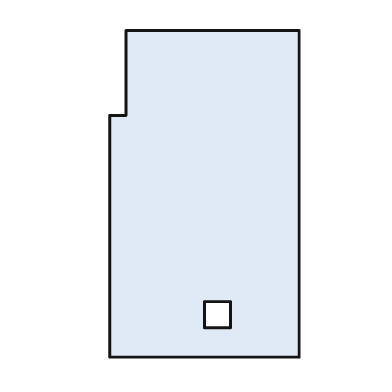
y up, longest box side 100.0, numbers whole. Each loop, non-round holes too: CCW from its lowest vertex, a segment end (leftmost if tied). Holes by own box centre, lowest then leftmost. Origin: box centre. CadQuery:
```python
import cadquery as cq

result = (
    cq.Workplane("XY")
    .moveTo(-29.0, -50.0)
    .lineTo(29.0, -50.0)
    .lineTo(29.0, 50.0)
    .lineTo(-24.0, 50.0)
    .lineTo(-24.0, 24.0)
    .lineTo(-29.0, 24.0)
    .close()
    .moveTo(0.0, -41.0)
    .lineTo(8.0, -41.0)
    .lineTo(8.0, -33.0)
    .lineTo(0.0, -33.0)
    .close()
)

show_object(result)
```